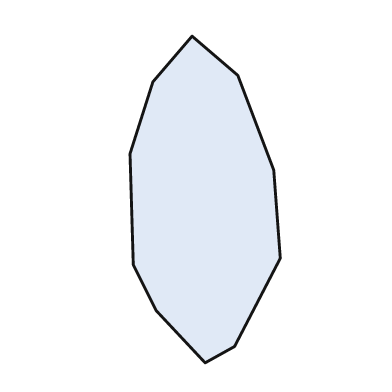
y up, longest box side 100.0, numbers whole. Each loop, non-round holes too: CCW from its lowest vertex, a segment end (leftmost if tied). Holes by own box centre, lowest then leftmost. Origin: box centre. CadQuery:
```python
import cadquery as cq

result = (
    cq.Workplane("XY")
    .moveTo(0.0, -50.0)
    .lineTo(9.0, -45.0)
    .lineTo(23.0, -18.0)
    .lineTo(21.0, 9.0)
    .lineTo(10.0, 38.0)
    .lineTo(-4.0, 50.0)
    .lineTo(-16.0, 36.0)
    .lineTo(-23.0, 14.0)
    .lineTo(-22.0, -20.0)
    .lineTo(-15.0, -34.0)
    .close()
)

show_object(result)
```